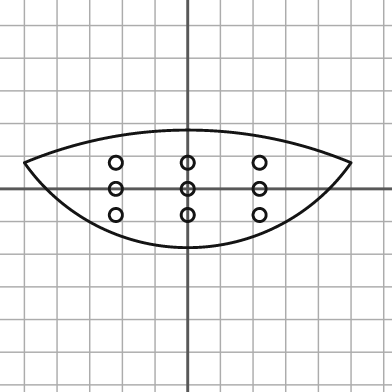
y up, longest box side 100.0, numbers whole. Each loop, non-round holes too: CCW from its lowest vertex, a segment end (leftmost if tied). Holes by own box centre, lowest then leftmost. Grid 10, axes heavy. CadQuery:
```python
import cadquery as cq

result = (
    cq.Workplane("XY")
    .moveTo(-50.0, 8.0)
    .threePointArc((0.0, -18.0), (50.0, 8.0))
    .threePointArc((0.0, 18.0), (-50.0, 8.0))
    .close()
    .moveTo(-22.0, -8.0)
    .circle(2.0)
    .moveTo(0.0, -8.0)
    .circle(2.0)
    .moveTo(22.0, -8.0)
    .circle(2.0)
    .moveTo(-22.0, 0.0)
    .circle(2.0)
    .moveTo(0.0, 0.0)
    .circle(2.0)
    .moveTo(22.0, 0.0)
    .circle(2.0)
    .moveTo(-22.0, 8.0)
    .circle(2.0)
    .moveTo(0.0, 8.0)
    .circle(2.0)
    .moveTo(22.0, 8.0)
    .circle(2.0)
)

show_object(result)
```